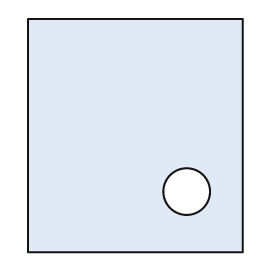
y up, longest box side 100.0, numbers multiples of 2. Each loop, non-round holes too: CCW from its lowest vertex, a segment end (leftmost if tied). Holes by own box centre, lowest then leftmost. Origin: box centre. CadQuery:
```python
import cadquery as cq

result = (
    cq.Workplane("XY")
    .moveTo(-46.0, -50.0)
    .lineTo(46.0, -50.0)
    .lineTo(46.0, 50.0)
    .lineTo(-46.0, 50.0)
    .close()
    .moveTo(22.0, -24.0)
    .circle(10.0)
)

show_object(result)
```